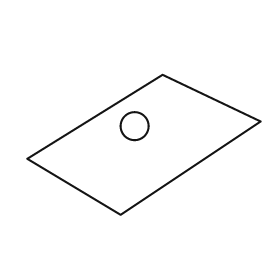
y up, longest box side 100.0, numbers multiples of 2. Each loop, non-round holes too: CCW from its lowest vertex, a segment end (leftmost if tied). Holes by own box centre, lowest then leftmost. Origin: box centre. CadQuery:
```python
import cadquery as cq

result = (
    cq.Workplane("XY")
    .moveTo(-10.0, -30.0)
    .lineTo(50.0, 10.0)
    .lineTo(8.0, 30.0)
    .lineTo(-50.0, -6.0)
    .close()
    .moveTo(-4.0, 8.0)
    .circle(6.0)
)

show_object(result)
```